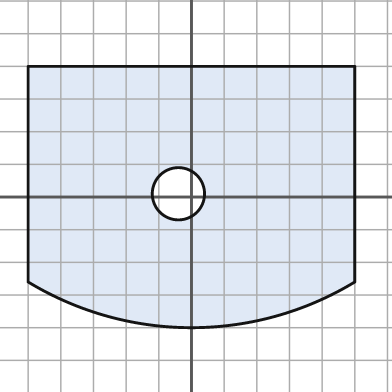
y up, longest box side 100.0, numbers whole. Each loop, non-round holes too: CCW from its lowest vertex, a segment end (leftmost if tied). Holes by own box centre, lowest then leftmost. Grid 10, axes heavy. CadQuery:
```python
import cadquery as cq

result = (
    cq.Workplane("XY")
    .moveTo(-50.0, -26.0)
    .threePointArc((0.0, -40.0), (50.0, -26.0))
    .lineTo(50.0, 40.0)
    .lineTo(-50.0, 40.0)
    .close()
    .moveTo(-4.0, 1.0)
    .circle(8.0)
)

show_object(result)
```